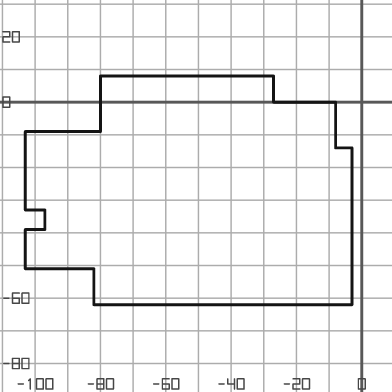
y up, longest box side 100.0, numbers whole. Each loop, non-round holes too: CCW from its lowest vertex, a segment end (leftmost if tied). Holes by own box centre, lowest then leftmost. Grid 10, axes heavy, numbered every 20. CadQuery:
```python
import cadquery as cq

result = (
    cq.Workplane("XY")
    .moveTo(-82.0, -62.0)
    .lineTo(-3.0, -62.0)
    .lineTo(-3.0, -14.0)
    .lineTo(-8.0, -14.0)
    .lineTo(-8.0, 0.0)
    .lineTo(-27.0, 0.0)
    .lineTo(-27.0, 8.0)
    .lineTo(-80.0, 8.0)
    .lineTo(-80.0, -9.0)
    .lineTo(-103.0, -9.0)
    .lineTo(-103.0, -33.0)
    .lineTo(-97.0, -33.0)
    .lineTo(-97.0, -39.0)
    .lineTo(-103.0, -39.0)
    .lineTo(-103.0, -51.0)
    .lineTo(-82.0, -51.0)
    .close()
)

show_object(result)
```